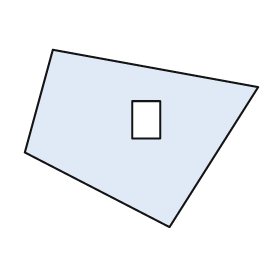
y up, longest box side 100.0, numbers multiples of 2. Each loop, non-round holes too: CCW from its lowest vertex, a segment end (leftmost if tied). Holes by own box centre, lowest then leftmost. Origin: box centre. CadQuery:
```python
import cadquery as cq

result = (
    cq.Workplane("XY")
    .moveTo(12.0, -38.0)
    .lineTo(50.0, 22.0)
    .lineTo(-38.0, 38.0)
    .lineTo(-50.0, -6.0)
    .close()
    .moveTo(-4.0, 0.0)
    .lineTo(8.0, 0.0)
    .lineTo(8.0, 16.0)
    .lineTo(-4.0, 16.0)
    .close()
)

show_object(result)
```